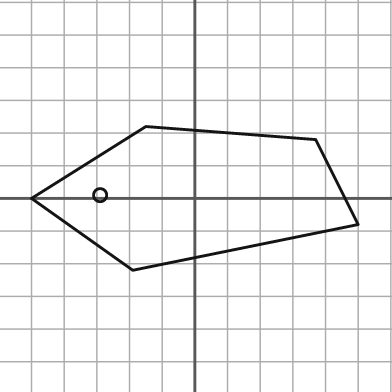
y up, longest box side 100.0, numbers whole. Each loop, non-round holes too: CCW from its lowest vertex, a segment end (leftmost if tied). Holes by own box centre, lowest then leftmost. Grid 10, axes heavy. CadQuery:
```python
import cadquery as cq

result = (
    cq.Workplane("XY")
    .moveTo(-19.0, -22.0)
    .lineTo(50.0, -8.0)
    .lineTo(37.0, 18.0)
    .lineTo(-15.0, 22.0)
    .lineTo(-50.0, 0.0)
    .close()
    .moveTo(-29.0, 1.0)
    .circle(2.0)
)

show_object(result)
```